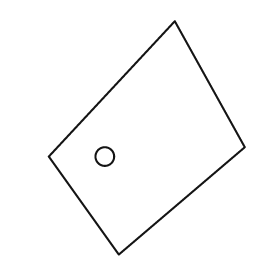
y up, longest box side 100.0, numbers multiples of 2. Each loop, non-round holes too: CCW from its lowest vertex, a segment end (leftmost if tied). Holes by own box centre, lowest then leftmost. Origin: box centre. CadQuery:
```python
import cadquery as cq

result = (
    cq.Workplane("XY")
    .moveTo(-12.0, -50.0)
    .lineTo(42.0, -4.0)
    .lineTo(12.0, 50.0)
    .lineTo(-42.0, -8.0)
    .close()
    .moveTo(-18.0, -8.0)
    .circle(4.0)
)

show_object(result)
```